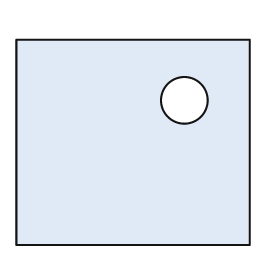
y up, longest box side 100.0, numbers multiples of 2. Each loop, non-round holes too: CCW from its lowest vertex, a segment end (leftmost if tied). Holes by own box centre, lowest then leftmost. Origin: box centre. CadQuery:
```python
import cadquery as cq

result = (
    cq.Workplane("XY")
    .moveTo(-50.0, -44.0)
    .lineTo(50.0, -44.0)
    .lineTo(50.0, 44.0)
    .lineTo(-50.0, 44.0)
    .close()
    .moveTo(22.0, 18.0)
    .circle(10.0)
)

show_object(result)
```